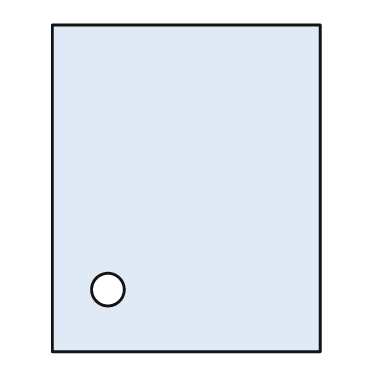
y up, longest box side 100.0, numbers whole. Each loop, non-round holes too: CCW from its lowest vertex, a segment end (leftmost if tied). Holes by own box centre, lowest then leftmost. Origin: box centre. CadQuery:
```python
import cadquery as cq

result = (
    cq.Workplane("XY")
    .moveTo(-41.0, -50.0)
    .lineTo(41.0, -50.0)
    .lineTo(41.0, 50.0)
    .lineTo(-41.0, 50.0)
    .close()
    .moveTo(-24.0, -31.0)
    .circle(5.0)
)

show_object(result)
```